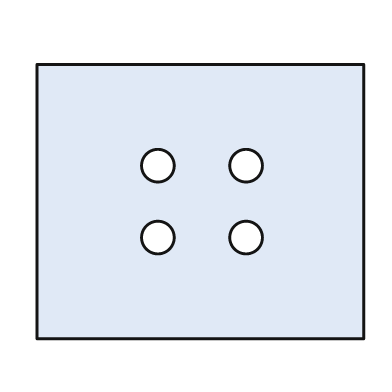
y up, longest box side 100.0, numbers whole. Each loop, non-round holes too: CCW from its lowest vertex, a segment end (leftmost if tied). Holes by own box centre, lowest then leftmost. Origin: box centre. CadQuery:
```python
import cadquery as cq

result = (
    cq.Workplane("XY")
    .moveTo(-50.0, -42.0)
    .lineTo(50.0, -42.0)
    .lineTo(50.0, 42.0)
    .lineTo(-50.0, 42.0)
    .close()
    .moveTo(-13.0, -11.0)
    .circle(5.0)
    .moveTo(14.0, -11.0)
    .circle(5.0)
    .moveTo(-13.0, 11.0)
    .circle(5.0)
    .moveTo(14.0, 11.0)
    .circle(5.0)
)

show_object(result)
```